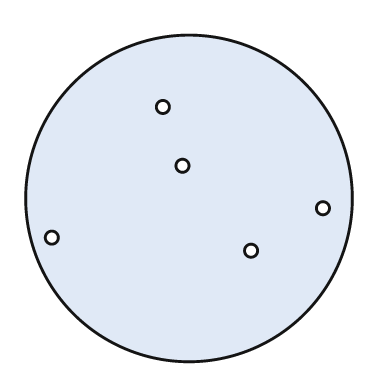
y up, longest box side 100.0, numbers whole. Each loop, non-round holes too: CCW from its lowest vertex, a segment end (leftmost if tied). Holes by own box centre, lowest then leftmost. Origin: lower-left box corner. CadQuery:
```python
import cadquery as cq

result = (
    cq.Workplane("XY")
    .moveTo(50.0, 50.0)
    .circle(50.0)
    .moveTo(69.0, 34.0)
    .circle(2.0)
    .moveTo(8.0, 38.0)
    .circle(2.0)
    .moveTo(91.0, 47.0)
    .circle(2.0)
    .moveTo(48.0, 60.0)
    .circle(2.0)
    .moveTo(42.0, 78.0)
    .circle(2.0)
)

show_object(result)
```